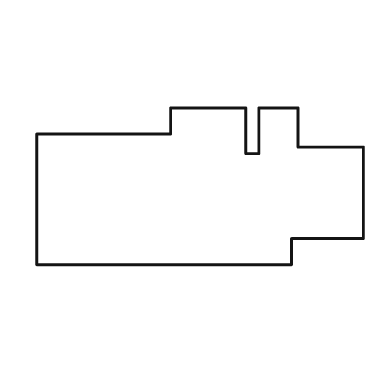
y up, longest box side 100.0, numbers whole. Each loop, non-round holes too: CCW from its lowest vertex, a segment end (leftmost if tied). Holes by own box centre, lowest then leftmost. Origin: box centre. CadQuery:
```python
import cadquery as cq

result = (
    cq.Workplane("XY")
    .moveTo(-50.0, -24.0)
    .lineTo(28.0, -24.0)
    .lineTo(28.0, -16.0)
    .lineTo(50.0, -16.0)
    .lineTo(50.0, 12.0)
    .lineTo(30.0, 12.0)
    .lineTo(30.0, 24.0)
    .lineTo(18.0, 24.0)
    .lineTo(18.0, 10.0)
    .lineTo(14.0, 10.0)
    .lineTo(14.0, 24.0)
    .lineTo(-9.0, 24.0)
    .lineTo(-9.0, 16.0)
    .lineTo(-50.0, 16.0)
    .close()
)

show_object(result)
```